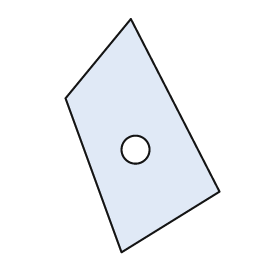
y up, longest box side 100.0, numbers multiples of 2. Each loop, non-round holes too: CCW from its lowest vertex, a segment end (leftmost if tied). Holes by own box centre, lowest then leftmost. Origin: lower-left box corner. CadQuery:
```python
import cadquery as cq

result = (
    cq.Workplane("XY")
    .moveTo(24.0, 0.0)
    .lineTo(66.0, 26.0)
    .lineTo(28.0, 100.0)
    .lineTo(0.0, 66.0)
    .close()
    .moveTo(30.0, 44.0)
    .circle(6.0)
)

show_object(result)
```